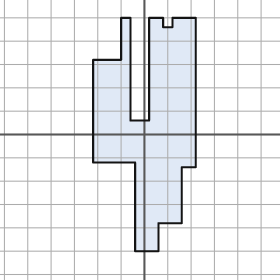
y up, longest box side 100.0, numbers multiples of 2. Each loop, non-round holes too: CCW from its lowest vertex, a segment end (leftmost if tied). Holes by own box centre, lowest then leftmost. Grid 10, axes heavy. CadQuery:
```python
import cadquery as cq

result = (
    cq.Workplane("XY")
    .moveTo(-4.0, -50.0)
    .lineTo(6.0, -50.0)
    .lineTo(6.0, -38.0)
    .lineTo(16.0, -38.0)
    .lineTo(16.0, -14.0)
    .lineTo(22.0, -14.0)
    .lineTo(22.0, 50.0)
    .lineTo(12.0, 50.0)
    .lineTo(12.0, 46.0)
    .lineTo(8.0, 46.0)
    .lineTo(8.0, 50.0)
    .lineTo(2.0, 50.0)
    .lineTo(2.0, 6.0)
    .lineTo(-6.0, 6.0)
    .lineTo(-6.0, 50.0)
    .lineTo(-10.0, 50.0)
    .lineTo(-10.0, 32.0)
    .lineTo(-22.0, 32.0)
    .lineTo(-22.0, -12.0)
    .lineTo(-4.0, -12.0)
    .close()
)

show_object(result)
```